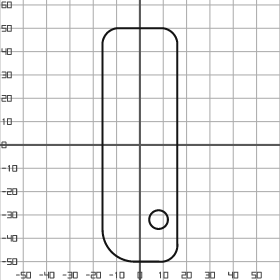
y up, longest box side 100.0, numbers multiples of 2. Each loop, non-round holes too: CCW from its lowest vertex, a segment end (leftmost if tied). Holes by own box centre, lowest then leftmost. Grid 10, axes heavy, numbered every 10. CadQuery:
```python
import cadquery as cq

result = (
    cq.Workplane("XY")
    .moveTo(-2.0, -50.0)
    .lineTo(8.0, -50.0)
    .threePointArc((14.0, -48.0), (16.0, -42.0))
    .lineTo(16.0, 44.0)
    .threePointArc((14.0, 48.0), (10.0, 50.0))
    .lineTo(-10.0, 50.0)
    .threePointArc((-14.0, 48.0), (-16.0, 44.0))
    .lineTo(-16.0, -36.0)
    .threePointArc((-12.0, -46.0), (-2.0, -50.0))
    .close()
    .moveTo(8.0, -32.0)
    .circle(4.0)
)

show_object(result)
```